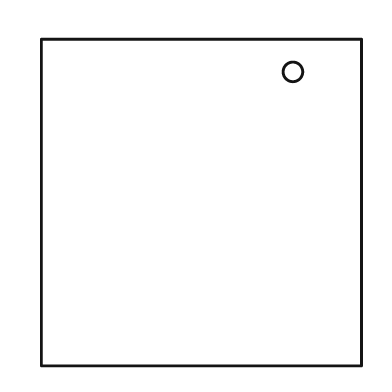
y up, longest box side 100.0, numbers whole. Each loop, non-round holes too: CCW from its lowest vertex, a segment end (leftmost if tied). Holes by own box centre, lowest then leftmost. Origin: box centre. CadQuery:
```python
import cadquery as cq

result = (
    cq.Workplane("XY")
    .moveTo(-49.0, -50.0)
    .lineTo(49.0, -50.0)
    .lineTo(49.0, 50.0)
    .lineTo(-49.0, 50.0)
    .close()
    .moveTo(28.0, 40.0)
    .circle(3.0)
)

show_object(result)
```